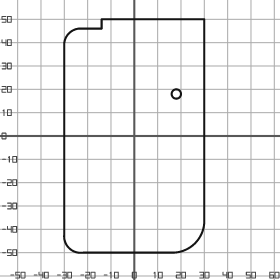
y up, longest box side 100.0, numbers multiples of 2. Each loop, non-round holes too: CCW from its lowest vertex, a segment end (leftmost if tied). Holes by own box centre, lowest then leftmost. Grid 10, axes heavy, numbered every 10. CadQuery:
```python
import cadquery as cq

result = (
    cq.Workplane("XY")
    .moveTo(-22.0, -50.0)
    .lineTo(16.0, -50.0)
    .threePointArc((26.0, -46.0), (30.0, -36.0))
    .lineTo(30.0, 50.0)
    .lineTo(-14.0, 50.0)
    .lineTo(-14.0, 46.0)
    .lineTo(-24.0, 46.0)
    .threePointArc((-28.0, 44.0), (-30.0, 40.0))
    .lineTo(-30.0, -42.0)
    .threePointArc((-28.0, -48.0), (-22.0, -50.0))
    .close()
    .moveTo(18.0, 18.0)
    .circle(2.0)
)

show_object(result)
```